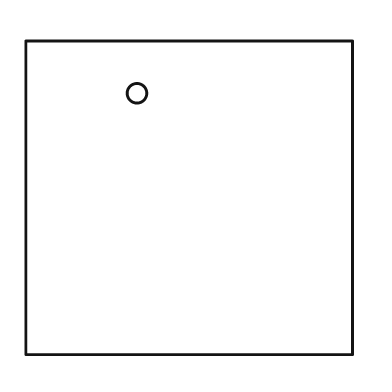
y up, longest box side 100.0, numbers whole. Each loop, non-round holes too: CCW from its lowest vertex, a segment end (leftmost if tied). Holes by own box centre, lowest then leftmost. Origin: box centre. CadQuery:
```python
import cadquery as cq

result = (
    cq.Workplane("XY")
    .moveTo(-50.0, -48.0)
    .lineTo(50.0, -48.0)
    .lineTo(50.0, 48.0)
    .lineTo(-50.0, 48.0)
    .close()
    .moveTo(-16.0, 32.0)
    .circle(3.0)
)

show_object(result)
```